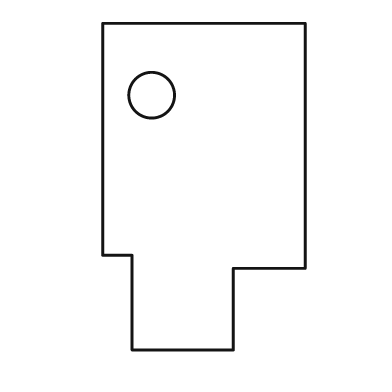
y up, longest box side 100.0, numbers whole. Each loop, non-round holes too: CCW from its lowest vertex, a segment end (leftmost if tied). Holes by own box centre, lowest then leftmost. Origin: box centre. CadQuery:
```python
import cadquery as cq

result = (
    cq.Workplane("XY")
    .moveTo(-22.0, -50.0)
    .lineTo(9.0, -50.0)
    .lineTo(9.0, -25.0)
    .lineTo(31.0, -25.0)
    .lineTo(31.0, 50.0)
    .lineTo(-31.0, 50.0)
    .lineTo(-31.0, -21.0)
    .lineTo(-22.0, -21.0)
    .close()
    .moveTo(-16.0, 28.0)
    .circle(7.0)
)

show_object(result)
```